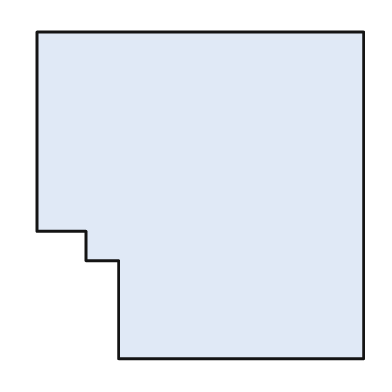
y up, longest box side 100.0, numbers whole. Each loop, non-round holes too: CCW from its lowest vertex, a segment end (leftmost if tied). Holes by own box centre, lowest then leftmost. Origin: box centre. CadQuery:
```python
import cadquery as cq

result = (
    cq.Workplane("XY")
    .moveTo(-25.0, -50.0)
    .lineTo(50.0, -50.0)
    .lineTo(50.0, 50.0)
    .lineTo(-50.0, 50.0)
    .lineTo(-50.0, -11.0)
    .lineTo(-35.0, -11.0)
    .lineTo(-35.0, -20.0)
    .lineTo(-25.0, -20.0)
    .close()
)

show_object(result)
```